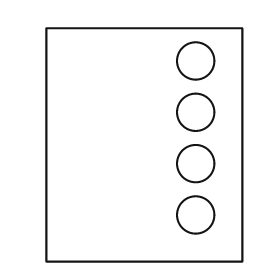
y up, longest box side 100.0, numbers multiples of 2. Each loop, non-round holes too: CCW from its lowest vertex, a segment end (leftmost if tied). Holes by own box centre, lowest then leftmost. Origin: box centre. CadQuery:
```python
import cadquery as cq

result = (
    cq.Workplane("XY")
    .moveTo(-42.0, -50.0)
    .lineTo(42.0, -50.0)
    .lineTo(42.0, 50.0)
    .lineTo(-42.0, 50.0)
    .close()
    .moveTo(22.0, -30.0)
    .circle(8.0)
    .moveTo(22.0, -8.0)
    .circle(8.0)
    .moveTo(22.0, 14.0)
    .circle(8.0)
    .moveTo(22.0, 36.0)
    .circle(8.0)
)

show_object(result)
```